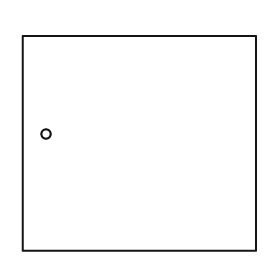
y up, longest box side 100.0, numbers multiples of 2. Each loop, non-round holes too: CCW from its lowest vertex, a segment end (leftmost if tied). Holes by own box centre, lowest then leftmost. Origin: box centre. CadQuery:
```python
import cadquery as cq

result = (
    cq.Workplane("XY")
    .moveTo(-50.0, -46.0)
    .lineTo(50.0, -46.0)
    .lineTo(50.0, 46.0)
    .lineTo(-50.0, 46.0)
    .close()
    .moveTo(-40.0, 4.0)
    .circle(2.0)
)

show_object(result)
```